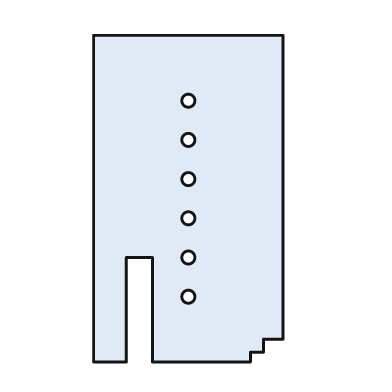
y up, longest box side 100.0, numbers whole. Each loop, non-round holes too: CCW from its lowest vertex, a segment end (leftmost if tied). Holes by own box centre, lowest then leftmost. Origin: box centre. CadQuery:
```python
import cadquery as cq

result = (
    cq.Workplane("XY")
    .moveTo(-29.0, -50.0)
    .lineTo(-19.0, -50.0)
    .lineTo(-19.0, -18.0)
    .lineTo(-11.0, -18.0)
    .lineTo(-11.0, -50.0)
    .lineTo(19.0, -50.0)
    .lineTo(19.0, -47.0)
    .lineTo(23.0, -47.0)
    .lineTo(23.0, -43.0)
    .lineTo(29.0, -43.0)
    .lineTo(29.0, 50.0)
    .lineTo(-29.0, 50.0)
    .close()
    .moveTo(0.0, -30.0)
    .circle(2.0)
    .moveTo(0.0, -18.0)
    .circle(2.0)
    .moveTo(0.0, -6.0)
    .circle(2.0)
    .moveTo(0.0, 6.0)
    .circle(2.0)
    .moveTo(0.0, 18.0)
    .circle(2.0)
    .moveTo(0.0, 30.0)
    .circle(2.0)
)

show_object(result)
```